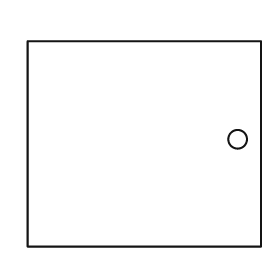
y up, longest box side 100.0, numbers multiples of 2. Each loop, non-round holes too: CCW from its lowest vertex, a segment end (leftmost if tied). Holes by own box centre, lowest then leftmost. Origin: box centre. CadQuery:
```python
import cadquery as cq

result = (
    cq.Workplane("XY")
    .moveTo(-50.0, -44.0)
    .lineTo(50.0, -44.0)
    .lineTo(50.0, 44.0)
    .lineTo(-50.0, 44.0)
    .close()
    .moveTo(40.0, 2.0)
    .circle(4.0)
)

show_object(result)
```